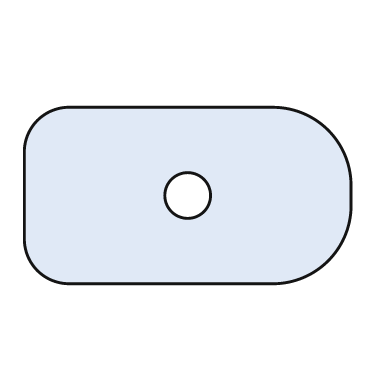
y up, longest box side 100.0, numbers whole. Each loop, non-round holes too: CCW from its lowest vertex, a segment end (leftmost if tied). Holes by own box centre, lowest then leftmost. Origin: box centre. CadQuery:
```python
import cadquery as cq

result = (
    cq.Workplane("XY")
    .moveTo(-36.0, -27.0)
    .lineTo(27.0, -27.0)
    .threePointArc((43.0, -20.0), (50.0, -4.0))
    .lineTo(50.0, 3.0)
    .threePointArc((43.0, 20.0), (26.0, 27.0))
    .lineTo(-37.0, 27.0)
    .threePointArc((-46.0, 23.0), (-50.0, 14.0))
    .lineTo(-50.0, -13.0)
    .threePointArc((-46.0, -23.0), (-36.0, -27.0))
    .close()
    .moveTo(0.0, 0.0)
    .circle(7.0)
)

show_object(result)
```